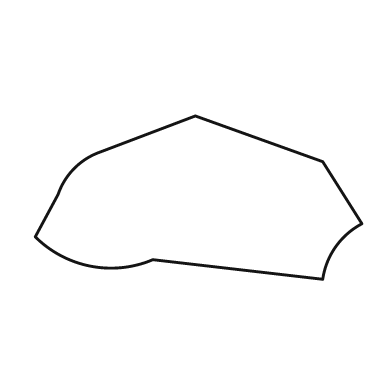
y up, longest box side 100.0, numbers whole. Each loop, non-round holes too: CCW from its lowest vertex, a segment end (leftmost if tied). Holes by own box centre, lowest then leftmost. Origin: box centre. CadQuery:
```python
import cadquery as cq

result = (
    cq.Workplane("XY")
    .moveTo(38.0, -25.0)
    .threePointArc((42.0, -15.0), (50.0, -8.0))
    .lineTo(38.0, 11.0)
    .lineTo(-1.0, 25.0)
    .lineTo(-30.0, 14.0)
    .threePointArc((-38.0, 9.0), (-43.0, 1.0))
    .lineTo(-50.0, -12.0)
    .threePointArc((-33.0, -21.0), (-14.0, -19.0))
    .close()
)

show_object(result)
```